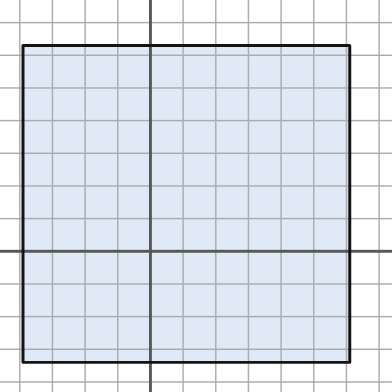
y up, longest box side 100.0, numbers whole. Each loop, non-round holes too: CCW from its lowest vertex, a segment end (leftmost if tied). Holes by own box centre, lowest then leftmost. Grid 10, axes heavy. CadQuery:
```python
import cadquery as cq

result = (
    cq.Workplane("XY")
    .moveTo(-39.0, -34.0)
    .lineTo(61.0, -34.0)
    .lineTo(61.0, 63.0)
    .lineTo(-39.0, 63.0)
    .close()
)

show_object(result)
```